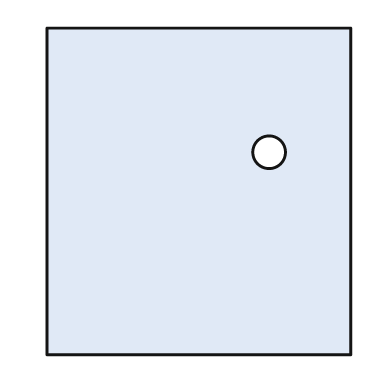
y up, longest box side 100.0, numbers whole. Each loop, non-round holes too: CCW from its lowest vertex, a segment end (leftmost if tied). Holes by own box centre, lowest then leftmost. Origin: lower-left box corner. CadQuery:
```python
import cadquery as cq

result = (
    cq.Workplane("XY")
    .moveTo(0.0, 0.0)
    .lineTo(93.0, 0.0)
    .lineTo(93.0, 100.0)
    .lineTo(0.0, 100.0)
    .close()
    .moveTo(68.0, 62.0)
    .circle(5.0)
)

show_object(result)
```